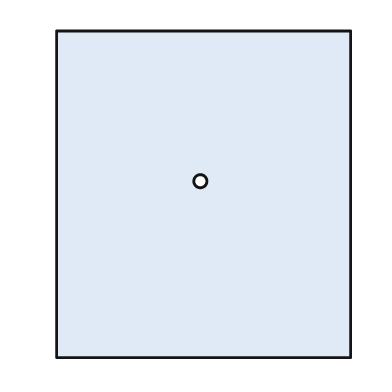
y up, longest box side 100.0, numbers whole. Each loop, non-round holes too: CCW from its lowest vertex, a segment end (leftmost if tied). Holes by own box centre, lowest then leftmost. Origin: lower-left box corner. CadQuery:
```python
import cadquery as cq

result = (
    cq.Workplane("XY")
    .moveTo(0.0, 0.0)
    .lineTo(90.0, 0.0)
    .lineTo(90.0, 100.0)
    .lineTo(0.0, 100.0)
    .close()
    .moveTo(44.0, 54.0)
    .circle(2.0)
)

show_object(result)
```